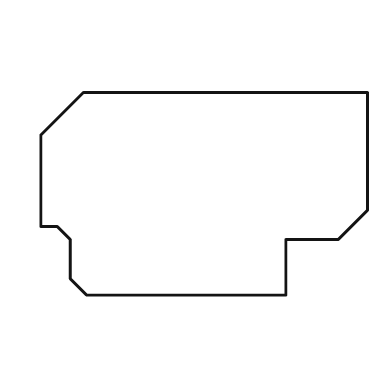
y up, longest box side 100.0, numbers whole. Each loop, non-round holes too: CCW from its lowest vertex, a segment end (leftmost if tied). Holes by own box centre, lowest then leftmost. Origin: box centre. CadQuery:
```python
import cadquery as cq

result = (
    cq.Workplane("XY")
    .moveTo(-36.0, -31.0)
    .lineTo(25.0, -31.0)
    .lineTo(25.0, -14.0)
    .lineTo(41.0, -14.0)
    .lineTo(50.0, -5.0)
    .lineTo(50.0, 31.0)
    .lineTo(-37.0, 31.0)
    .lineTo(-50.0, 18.0)
    .lineTo(-50.0, -10.0)
    .lineTo(-45.0, -10.0)
    .lineTo(-41.0, -14.0)
    .lineTo(-41.0, -26.0)
    .close()
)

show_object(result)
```